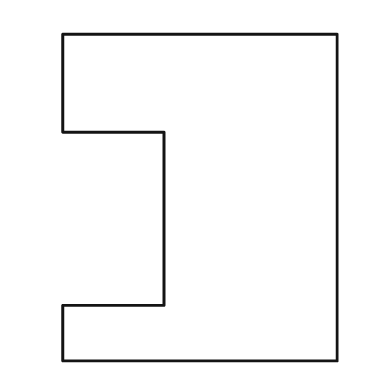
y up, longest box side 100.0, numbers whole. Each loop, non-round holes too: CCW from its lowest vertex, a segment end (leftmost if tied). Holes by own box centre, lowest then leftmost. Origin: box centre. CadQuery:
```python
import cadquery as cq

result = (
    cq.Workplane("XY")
    .moveTo(-42.0, -50.0)
    .lineTo(42.0, -50.0)
    .lineTo(42.0, 50.0)
    .lineTo(-42.0, 50.0)
    .lineTo(-42.0, 20.0)
    .lineTo(-11.0, 20.0)
    .lineTo(-11.0, -33.0)
    .lineTo(-42.0, -33.0)
    .close()
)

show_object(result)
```